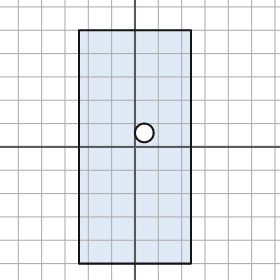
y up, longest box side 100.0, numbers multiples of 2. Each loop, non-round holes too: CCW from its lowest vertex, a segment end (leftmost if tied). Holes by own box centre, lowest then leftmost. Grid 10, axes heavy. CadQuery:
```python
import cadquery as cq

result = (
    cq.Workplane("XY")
    .moveTo(-24.0, -50.0)
    .lineTo(24.0, -50.0)
    .lineTo(24.0, 50.0)
    .lineTo(-24.0, 50.0)
    .close()
    .moveTo(4.0, 6.0)
    .circle(4.0)
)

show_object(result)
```